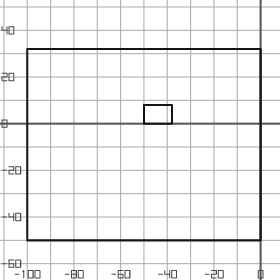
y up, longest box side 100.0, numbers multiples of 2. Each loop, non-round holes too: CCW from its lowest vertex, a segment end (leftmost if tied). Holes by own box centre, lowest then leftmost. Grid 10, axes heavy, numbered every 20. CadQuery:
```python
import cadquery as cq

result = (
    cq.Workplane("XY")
    .moveTo(-100.0, -50.0)
    .lineTo(0.0, -50.0)
    .lineTo(0.0, 32.0)
    .lineTo(-100.0, 32.0)
    .close()
    .moveTo(-50.0, 0.0)
    .lineTo(-38.0, 0.0)
    .lineTo(-38.0, 8.0)
    .lineTo(-50.0, 8.0)
    .close()
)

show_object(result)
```